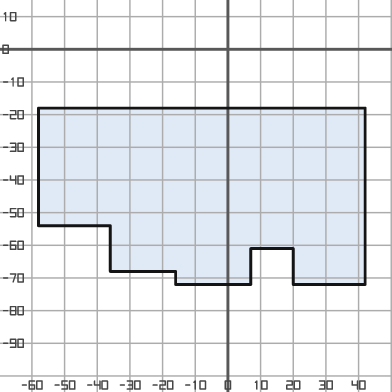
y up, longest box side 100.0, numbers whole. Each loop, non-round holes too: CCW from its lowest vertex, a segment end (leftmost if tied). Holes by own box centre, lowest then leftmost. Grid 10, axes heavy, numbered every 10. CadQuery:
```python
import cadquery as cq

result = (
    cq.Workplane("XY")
    .moveTo(-16.0, -72.0)
    .lineTo(7.0, -72.0)
    .lineTo(7.0, -61.0)
    .lineTo(20.0, -61.0)
    .lineTo(20.0, -72.0)
    .lineTo(42.0, -72.0)
    .lineTo(42.0, -18.0)
    .lineTo(-58.0, -18.0)
    .lineTo(-58.0, -54.0)
    .lineTo(-36.0, -54.0)
    .lineTo(-36.0, -68.0)
    .lineTo(-16.0, -68.0)
    .close()
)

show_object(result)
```